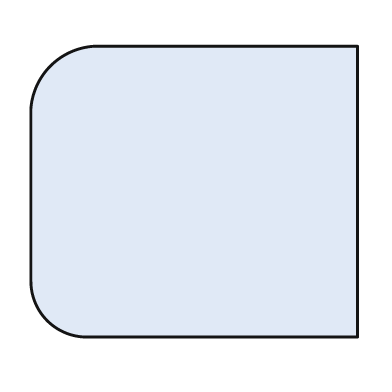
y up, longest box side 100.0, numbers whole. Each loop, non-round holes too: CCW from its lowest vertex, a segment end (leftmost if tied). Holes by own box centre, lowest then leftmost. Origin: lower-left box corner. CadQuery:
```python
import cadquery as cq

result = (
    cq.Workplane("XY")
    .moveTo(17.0, 0.0)
    .lineTo(100.0, 0.0)
    .lineTo(100.0, 89.0)
    .lineTo(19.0, 89.0)
    .threePointArc((6.0, 83.0), (0.0, 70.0))
    .lineTo(0.0, 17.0)
    .threePointArc((5.0, 5.0), (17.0, 0.0))
    .close()
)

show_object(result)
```